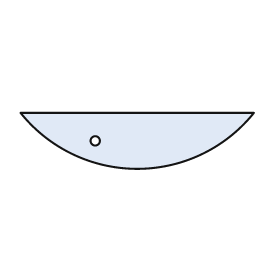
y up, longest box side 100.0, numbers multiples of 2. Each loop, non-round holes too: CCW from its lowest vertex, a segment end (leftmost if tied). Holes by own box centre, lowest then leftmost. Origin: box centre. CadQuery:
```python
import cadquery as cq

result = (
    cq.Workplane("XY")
    .moveTo(-50.0, 12.0)
    .threePointArc((0.0, -12.0), (50.0, 12.0))
    .close()
    .moveTo(-18.0, 0.0)
    .circle(2.0)
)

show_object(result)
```